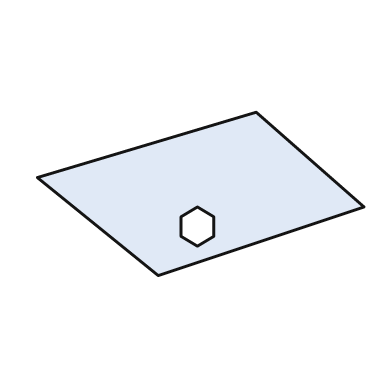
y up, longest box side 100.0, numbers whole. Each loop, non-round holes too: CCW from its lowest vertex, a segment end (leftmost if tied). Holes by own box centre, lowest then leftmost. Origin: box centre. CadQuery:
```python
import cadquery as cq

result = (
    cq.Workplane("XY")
    .moveTo(-13.0, -25.0)
    .lineTo(50.0, -4.0)
    .lineTo(17.0, 25.0)
    .lineTo(-50.0, 5.0)
    .close()
    .moveTo(-1.0, -16.0)
    .lineTo(4.0, -13.0)
    .lineTo(4.0, -7.0)
    .lineTo(-1.0, -4.0)
    .lineTo(-6.0, -7.0)
    .lineTo(-6.0, -13.0)
    .close()
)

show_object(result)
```